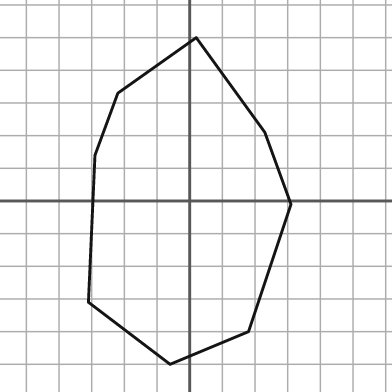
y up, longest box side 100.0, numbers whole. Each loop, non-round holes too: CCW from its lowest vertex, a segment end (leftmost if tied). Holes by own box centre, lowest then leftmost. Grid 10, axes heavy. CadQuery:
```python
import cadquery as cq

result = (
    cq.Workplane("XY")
    .moveTo(-6.0, -50.0)
    .lineTo(18.0, -40.0)
    .lineTo(31.0, -1.0)
    .lineTo(23.0, 21.0)
    .lineTo(2.0, 50.0)
    .lineTo(-22.0, 33.0)
    .lineTo(-29.0, 14.0)
    .lineTo(-31.0, -31.0)
    .close()
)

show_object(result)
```